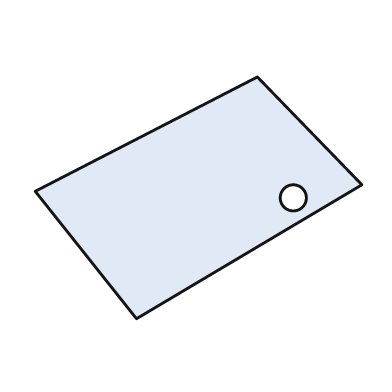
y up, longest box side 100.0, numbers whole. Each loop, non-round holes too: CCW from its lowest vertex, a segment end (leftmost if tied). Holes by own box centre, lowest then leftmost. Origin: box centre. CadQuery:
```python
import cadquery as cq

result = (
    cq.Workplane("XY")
    .moveTo(-19.0, -37.0)
    .lineTo(50.0, 4.0)
    .lineTo(18.0, 37.0)
    .lineTo(-50.0, 2.0)
    .close()
    .moveTo(29.0, 0.0)
    .circle(4.0)
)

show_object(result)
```